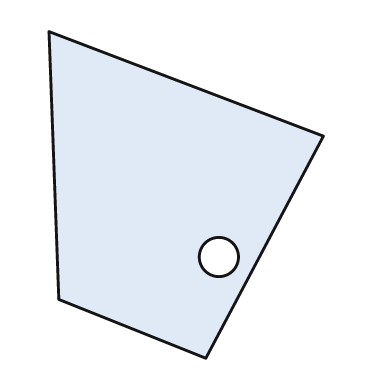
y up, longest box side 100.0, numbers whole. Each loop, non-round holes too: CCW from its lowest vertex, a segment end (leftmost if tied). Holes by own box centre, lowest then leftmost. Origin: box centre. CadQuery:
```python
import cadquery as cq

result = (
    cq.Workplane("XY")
    .moveTo(6.0, -50.0)
    .lineTo(42.0, 18.0)
    .lineTo(-42.0, 50.0)
    .lineTo(-39.0, -32.0)
    .close()
    .moveTo(10.0, -19.0)
    .circle(6.0)
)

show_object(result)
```